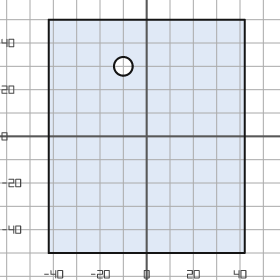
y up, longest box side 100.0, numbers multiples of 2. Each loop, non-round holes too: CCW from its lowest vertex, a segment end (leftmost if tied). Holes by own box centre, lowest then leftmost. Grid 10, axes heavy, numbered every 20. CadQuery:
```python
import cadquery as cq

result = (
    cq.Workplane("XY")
    .moveTo(-42.0, -50.0)
    .lineTo(42.0, -50.0)
    .lineTo(42.0, 50.0)
    .lineTo(-42.0, 50.0)
    .close()
    .moveTo(-10.0, 30.0)
    .circle(4.0)
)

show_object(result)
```